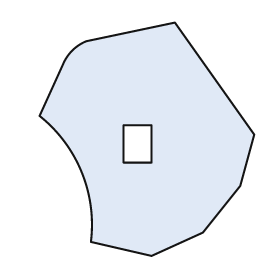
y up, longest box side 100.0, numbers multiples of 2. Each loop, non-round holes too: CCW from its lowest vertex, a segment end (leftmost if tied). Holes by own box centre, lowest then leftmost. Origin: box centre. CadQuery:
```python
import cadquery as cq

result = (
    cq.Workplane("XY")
    .moveTo(2.0, -50.0)
    .lineTo(24.0, -40.0)
    .lineTo(40.0, -20.0)
    .lineTo(46.0, 2.0)
    .lineTo(12.0, 50.0)
    .lineTo(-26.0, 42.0)
    .threePointArc((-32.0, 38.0), (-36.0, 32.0))
    .lineTo(-46.0, 10.0)
    .threePointArc((-28.0, -14.0), (-24.0, -44.0))
    .close()
    .moveTo(-10.0, -10.0)
    .lineTo(2.0, -10.0)
    .lineTo(2.0, 6.0)
    .lineTo(-10.0, 6.0)
    .close()
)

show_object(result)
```